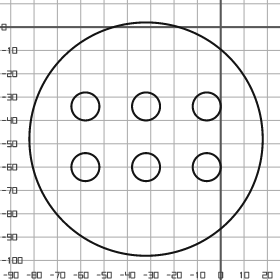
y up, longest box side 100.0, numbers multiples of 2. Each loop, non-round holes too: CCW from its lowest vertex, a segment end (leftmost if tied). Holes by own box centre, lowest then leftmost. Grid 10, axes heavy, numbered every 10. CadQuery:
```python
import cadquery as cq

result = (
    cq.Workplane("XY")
    .moveTo(-32.0, -48.0)
    .circle(50.0)
    .moveTo(-58.0, -60.0)
    .circle(6.0)
    .moveTo(-32.0, -60.0)
    .circle(6.0)
    .moveTo(-6.0, -60.0)
    .circle(6.0)
    .moveTo(-58.0, -34.0)
    .circle(6.0)
    .moveTo(-32.0, -34.0)
    .circle(6.0)
    .moveTo(-6.0, -34.0)
    .circle(6.0)
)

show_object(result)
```